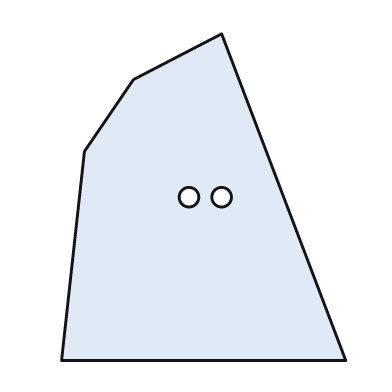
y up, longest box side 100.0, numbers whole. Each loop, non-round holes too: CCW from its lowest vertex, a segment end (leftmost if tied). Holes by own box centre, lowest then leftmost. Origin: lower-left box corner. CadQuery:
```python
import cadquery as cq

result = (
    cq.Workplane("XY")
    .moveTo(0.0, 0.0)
    .lineTo(87.0, 0.0)
    .lineTo(49.0, 100.0)
    .lineTo(22.0, 86.0)
    .lineTo(7.0, 64.0)
    .close()
    .moveTo(39.0, 50.0)
    .circle(3.0)
    .moveTo(49.0, 50.0)
    .circle(3.0)
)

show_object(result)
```